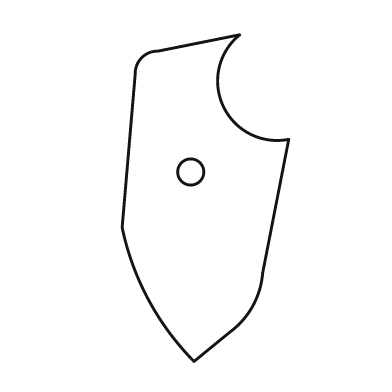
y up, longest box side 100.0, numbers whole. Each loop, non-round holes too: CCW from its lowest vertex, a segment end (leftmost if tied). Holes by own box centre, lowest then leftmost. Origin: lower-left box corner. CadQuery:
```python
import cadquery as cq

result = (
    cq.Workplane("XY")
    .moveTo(22.0, 0.0)
    .lineTo(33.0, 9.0)
    .threePointArc((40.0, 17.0), (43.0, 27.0))
    .lineTo(51.0, 68.0)
    .threePointArc((31.0, 78.0), (36.0, 100.0))
    .lineTo(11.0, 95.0)
    .threePointArc((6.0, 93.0), (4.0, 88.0))
    .lineTo(0.0, 41.0)
    .threePointArc((8.0, 19.0), (22.0, 0.0))
    .close()
    .moveTo(21.0, 58.0)
    .circle(4.0)
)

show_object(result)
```